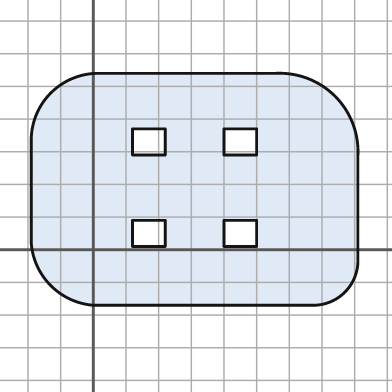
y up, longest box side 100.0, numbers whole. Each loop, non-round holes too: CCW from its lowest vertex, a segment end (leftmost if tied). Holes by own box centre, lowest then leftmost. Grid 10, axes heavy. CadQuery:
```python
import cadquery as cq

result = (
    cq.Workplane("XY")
    .moveTo(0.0, -17.0)
    .lineTo(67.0, -17.0)
    .threePointArc((77.0, -13.0), (81.0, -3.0))
    .lineTo(81.0, 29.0)
    .threePointArc((74.0, 47.0), (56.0, 54.0))
    .lineTo(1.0, 54.0)
    .threePointArc((-13.0, 48.0), (-19.0, 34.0))
    .lineTo(-19.0, 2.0)
    .threePointArc((-13.0, -11.0), (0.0, -17.0))
    .close()
    .moveTo(12.0, 1.0)
    .lineTo(22.0, 1.0)
    .lineTo(22.0, 9.0)
    .lineTo(12.0, 9.0)
    .close()
    .moveTo(40.0, 1.0)
    .lineTo(50.0, 1.0)
    .lineTo(50.0, 9.0)
    .lineTo(40.0, 9.0)
    .close()
    .moveTo(12.0, 29.0)
    .lineTo(22.0, 29.0)
    .lineTo(22.0, 37.0)
    .lineTo(12.0, 37.0)
    .close()
    .moveTo(40.0, 29.0)
    .lineTo(50.0, 29.0)
    .lineTo(50.0, 37.0)
    .lineTo(40.0, 37.0)
    .close()
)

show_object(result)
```